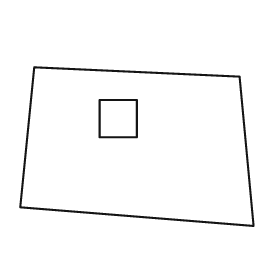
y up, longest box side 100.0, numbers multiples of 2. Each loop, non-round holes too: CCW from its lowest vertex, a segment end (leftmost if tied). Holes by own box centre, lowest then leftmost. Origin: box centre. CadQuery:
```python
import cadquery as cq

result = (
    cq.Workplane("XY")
    .moveTo(50.0, -34.0)
    .lineTo(44.0, 30.0)
    .lineTo(-44.0, 34.0)
    .lineTo(-50.0, -26.0)
    .close()
    .moveTo(-16.0, 4.0)
    .lineTo(0.0, 4.0)
    .lineTo(0.0, 20.0)
    .lineTo(-16.0, 20.0)
    .close()
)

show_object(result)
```